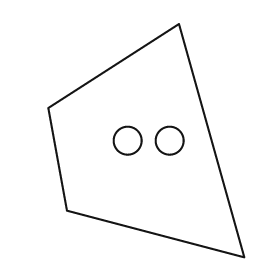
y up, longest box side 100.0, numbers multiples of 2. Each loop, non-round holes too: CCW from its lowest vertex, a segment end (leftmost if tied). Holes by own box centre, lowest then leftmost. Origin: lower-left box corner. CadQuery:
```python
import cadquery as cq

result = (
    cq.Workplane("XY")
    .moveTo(84.0, 0.0)
    .lineTo(56.0, 100.0)
    .lineTo(0.0, 64.0)
    .lineTo(8.0, 20.0)
    .close()
    .moveTo(34.0, 50.0)
    .circle(6.0)
    .moveTo(52.0, 50.0)
    .circle(6.0)
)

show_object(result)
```